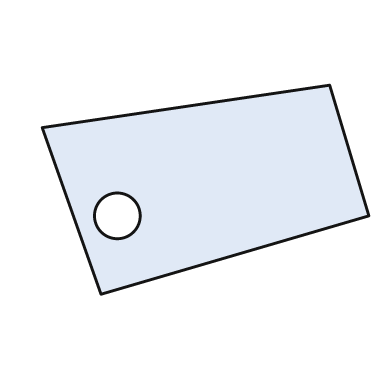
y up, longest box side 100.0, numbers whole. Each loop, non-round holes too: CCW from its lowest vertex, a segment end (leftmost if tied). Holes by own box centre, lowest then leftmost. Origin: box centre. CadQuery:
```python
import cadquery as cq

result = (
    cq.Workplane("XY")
    .moveTo(-32.0, -32.0)
    .lineTo(50.0, -8.0)
    .lineTo(38.0, 32.0)
    .lineTo(-50.0, 19.0)
    .close()
    .moveTo(-27.0, -8.0)
    .circle(7.0)
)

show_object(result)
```